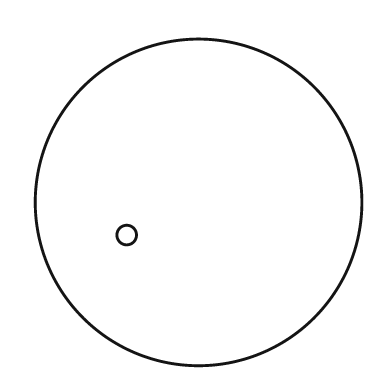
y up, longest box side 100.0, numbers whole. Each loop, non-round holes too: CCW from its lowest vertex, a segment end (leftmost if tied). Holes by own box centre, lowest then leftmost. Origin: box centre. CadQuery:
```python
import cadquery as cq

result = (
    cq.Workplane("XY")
    .moveTo(0.0, 0.0)
    .circle(50.0)
    .moveTo(-22.0, -10.0)
    .circle(3.0)
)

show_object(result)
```